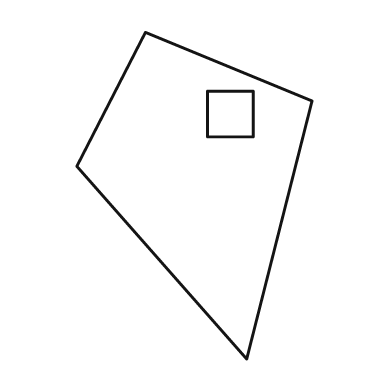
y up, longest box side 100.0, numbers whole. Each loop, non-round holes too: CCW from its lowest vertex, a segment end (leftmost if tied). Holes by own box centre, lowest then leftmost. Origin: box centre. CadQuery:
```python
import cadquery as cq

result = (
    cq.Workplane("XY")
    .moveTo(16.0, -50.0)
    .lineTo(36.0, 29.0)
    .lineTo(-15.0, 50.0)
    .lineTo(-36.0, 9.0)
    .close()
    .moveTo(4.0, 18.0)
    .lineTo(18.0, 18.0)
    .lineTo(18.0, 32.0)
    .lineTo(4.0, 32.0)
    .close()
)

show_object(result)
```